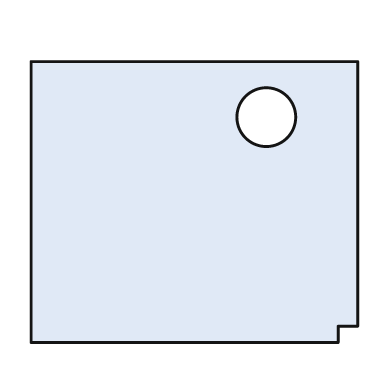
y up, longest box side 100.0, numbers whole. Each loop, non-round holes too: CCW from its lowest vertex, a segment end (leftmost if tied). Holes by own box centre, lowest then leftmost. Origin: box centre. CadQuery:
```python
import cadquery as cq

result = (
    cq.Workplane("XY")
    .moveTo(-50.0, -43.0)
    .lineTo(44.0, -43.0)
    .lineTo(44.0, -38.0)
    .lineTo(50.0, -38.0)
    .lineTo(50.0, 43.0)
    .lineTo(-50.0, 43.0)
    .close()
    .moveTo(22.0, 26.0)
    .circle(9.0)
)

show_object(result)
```